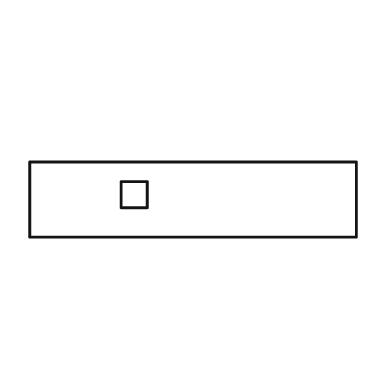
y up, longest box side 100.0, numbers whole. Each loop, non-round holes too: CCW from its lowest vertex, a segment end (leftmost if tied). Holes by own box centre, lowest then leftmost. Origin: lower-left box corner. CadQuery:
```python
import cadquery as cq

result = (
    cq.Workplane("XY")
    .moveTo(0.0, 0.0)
    .lineTo(100.0, 0.0)
    .lineTo(100.0, 23.0)
    .lineTo(0.0, 23.0)
    .close()
    .moveTo(28.0, 9.0)
    .lineTo(36.0, 9.0)
    .lineTo(36.0, 17.0)
    .lineTo(28.0, 17.0)
    .close()
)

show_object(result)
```